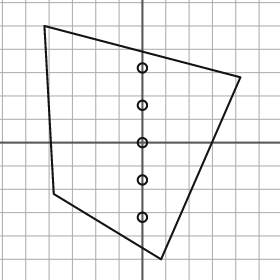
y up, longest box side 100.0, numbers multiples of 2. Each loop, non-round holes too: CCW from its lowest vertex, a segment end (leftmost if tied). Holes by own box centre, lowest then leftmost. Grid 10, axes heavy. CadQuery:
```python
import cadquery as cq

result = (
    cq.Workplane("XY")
    .moveTo(8.0, -50.0)
    .lineTo(42.0, 28.0)
    .lineTo(-42.0, 50.0)
    .lineTo(-38.0, -22.0)
    .close()
    .moveTo(0.0, -32.0)
    .circle(2.0)
    .moveTo(0.0, -16.0)
    .circle(2.0)
    .moveTo(0.0, 0.0)
    .circle(2.0)
    .moveTo(0.0, 16.0)
    .circle(2.0)
    .moveTo(0.0, 32.0)
    .circle(2.0)
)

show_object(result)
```